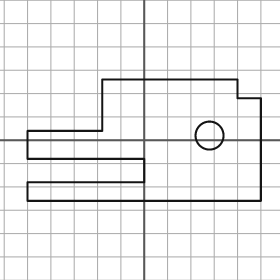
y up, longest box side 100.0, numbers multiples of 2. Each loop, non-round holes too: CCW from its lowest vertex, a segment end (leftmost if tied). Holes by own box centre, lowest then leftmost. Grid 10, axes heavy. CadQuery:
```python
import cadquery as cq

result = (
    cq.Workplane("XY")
    .moveTo(-50.0, -26.0)
    .lineTo(50.0, -26.0)
    .lineTo(50.0, 18.0)
    .lineTo(40.0, 18.0)
    .lineTo(40.0, 26.0)
    .lineTo(-18.0, 26.0)
    .lineTo(-18.0, 4.0)
    .lineTo(-50.0, 4.0)
    .lineTo(-50.0, -8.0)
    .lineTo(0.0, -8.0)
    .lineTo(0.0, -18.0)
    .lineTo(-50.0, -18.0)
    .close()
    .moveTo(28.0, 2.0)
    .circle(6.0)
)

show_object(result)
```